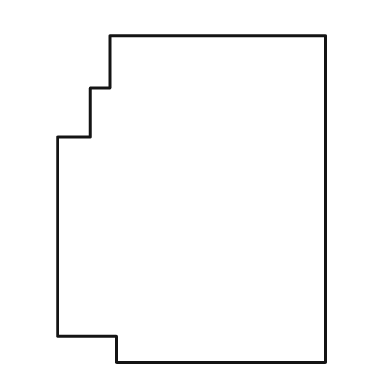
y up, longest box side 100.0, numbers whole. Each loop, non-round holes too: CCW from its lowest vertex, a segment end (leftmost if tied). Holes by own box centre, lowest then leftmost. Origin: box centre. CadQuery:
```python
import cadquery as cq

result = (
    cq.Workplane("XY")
    .moveTo(-23.0, -50.0)
    .lineTo(41.0, -50.0)
    .lineTo(41.0, 50.0)
    .lineTo(-25.0, 50.0)
    .lineTo(-25.0, 34.0)
    .lineTo(-31.0, 34.0)
    .lineTo(-31.0, 19.0)
    .lineTo(-41.0, 19.0)
    .lineTo(-41.0, -42.0)
    .lineTo(-23.0, -42.0)
    .close()
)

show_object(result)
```